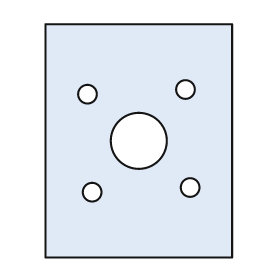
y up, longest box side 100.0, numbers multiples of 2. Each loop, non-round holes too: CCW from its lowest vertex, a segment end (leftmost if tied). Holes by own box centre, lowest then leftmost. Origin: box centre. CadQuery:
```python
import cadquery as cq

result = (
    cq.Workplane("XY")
    .moveTo(-40.0, -50.0)
    .lineTo(40.0, -50.0)
    .lineTo(40.0, 50.0)
    .lineTo(-40.0, 50.0)
    .close()
    .moveTo(-20.0, -22.0)
    .circle(4.0)
    .moveTo(22.0, -20.0)
    .circle(4.0)
    .moveTo(0.0, 0.0)
    .circle(12.0)
    .moveTo(-22.0, 20.0)
    .circle(4.0)
    .moveTo(20.0, 22.0)
    .circle(4.0)
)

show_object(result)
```